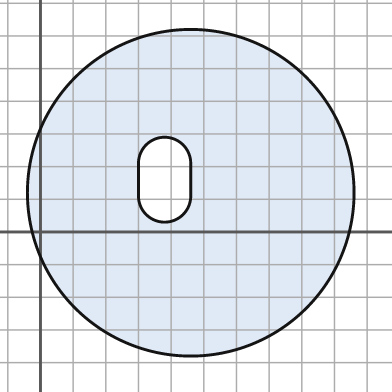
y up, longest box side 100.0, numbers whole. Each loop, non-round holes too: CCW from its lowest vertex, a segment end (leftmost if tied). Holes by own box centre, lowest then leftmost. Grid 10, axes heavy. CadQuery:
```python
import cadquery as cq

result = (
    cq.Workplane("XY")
    .moveTo(46.0, 12.0)
    .circle(50.0)
    .moveTo(30.0, 11.0)
    .threePointArc((38.0, 3.0), (46.0, 11.0))
    .lineTo(46.0, 21.0)
    .threePointArc((38.0, 29.0), (30.0, 21.0))
    .close()
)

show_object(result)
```